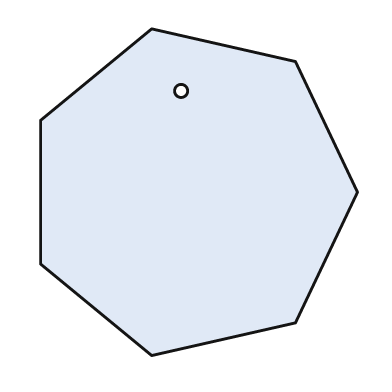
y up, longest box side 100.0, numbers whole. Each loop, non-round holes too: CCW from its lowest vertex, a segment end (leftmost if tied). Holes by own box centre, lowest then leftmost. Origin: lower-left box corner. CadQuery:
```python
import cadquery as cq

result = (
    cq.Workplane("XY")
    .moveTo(34.0, 0.0)
    .lineTo(78.0, 10.0)
    .lineTo(97.0, 50.0)
    .lineTo(78.0, 90.0)
    .lineTo(34.0, 100.0)
    .lineTo(0.0, 72.0)
    .lineTo(0.0, 28.0)
    .close()
    .moveTo(43.0, 81.0)
    .circle(2.0)
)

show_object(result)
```